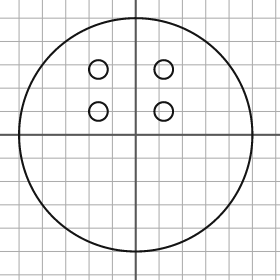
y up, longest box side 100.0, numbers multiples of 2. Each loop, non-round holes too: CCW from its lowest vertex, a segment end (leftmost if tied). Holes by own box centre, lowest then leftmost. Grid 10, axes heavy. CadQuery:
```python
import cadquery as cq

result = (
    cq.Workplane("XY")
    .moveTo(0.0, 0.0)
    .circle(50.0)
    .moveTo(-16.0, 10.0)
    .circle(4.0)
    .moveTo(12.0, 10.0)
    .circle(4.0)
    .moveTo(-16.0, 28.0)
    .circle(4.0)
    .moveTo(12.0, 28.0)
    .circle(4.0)
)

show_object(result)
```